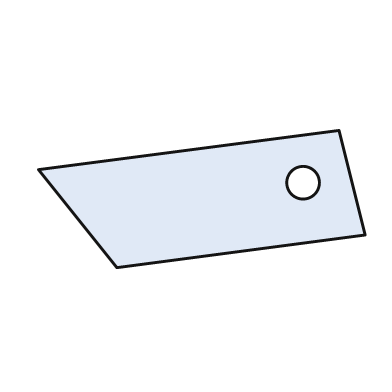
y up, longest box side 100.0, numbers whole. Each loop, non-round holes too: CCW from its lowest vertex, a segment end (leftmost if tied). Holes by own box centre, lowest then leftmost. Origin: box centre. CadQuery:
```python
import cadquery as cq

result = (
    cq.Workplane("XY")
    .moveTo(-26.0, -21.0)
    .lineTo(50.0, -11.0)
    .lineTo(42.0, 21.0)
    .lineTo(-50.0, 9.0)
    .close()
    .moveTo(31.0, 5.0)
    .circle(5.0)
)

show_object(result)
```